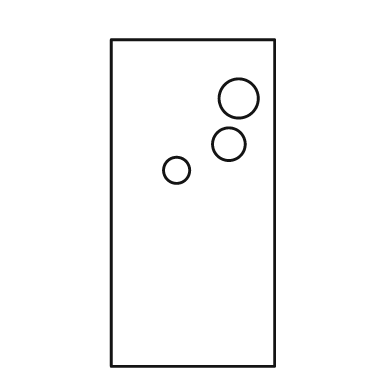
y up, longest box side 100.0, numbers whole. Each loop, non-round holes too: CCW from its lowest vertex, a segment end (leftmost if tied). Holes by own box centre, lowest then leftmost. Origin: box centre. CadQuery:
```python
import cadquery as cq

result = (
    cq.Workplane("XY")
    .moveTo(-25.0, -50.0)
    .lineTo(25.0, -50.0)
    .lineTo(25.0, 50.0)
    .lineTo(-25.0, 50.0)
    .close()
    .moveTo(-5.0, 10.0)
    .circle(4.0)
    .moveTo(11.0, 18.0)
    .circle(5.0)
    .moveTo(14.0, 32.0)
    .circle(6.0)
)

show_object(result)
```